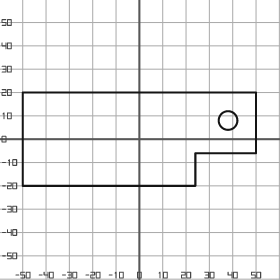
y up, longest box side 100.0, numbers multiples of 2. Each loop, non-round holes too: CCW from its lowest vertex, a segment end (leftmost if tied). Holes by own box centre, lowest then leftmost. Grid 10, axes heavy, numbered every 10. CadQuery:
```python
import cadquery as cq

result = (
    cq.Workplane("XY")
    .moveTo(-50.0, -20.0)
    .lineTo(24.0, -20.0)
    .lineTo(24.0, -6.0)
    .lineTo(50.0, -6.0)
    .lineTo(50.0, 20.0)
    .lineTo(-50.0, 20.0)
    .close()
    .moveTo(38.0, 8.0)
    .circle(4.0)
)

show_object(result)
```